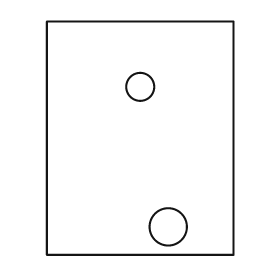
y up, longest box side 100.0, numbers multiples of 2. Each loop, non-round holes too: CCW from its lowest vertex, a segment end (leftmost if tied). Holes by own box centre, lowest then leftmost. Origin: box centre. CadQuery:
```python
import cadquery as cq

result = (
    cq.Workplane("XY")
    .moveTo(-40.0, -50.0)
    .lineTo(40.0, -50.0)
    .lineTo(40.0, 50.0)
    .lineTo(-40.0, 50.0)
    .close()
    .moveTo(12.0, -38.0)
    .circle(8.0)
    .moveTo(0.0, 22.0)
    .circle(6.0)
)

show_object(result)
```